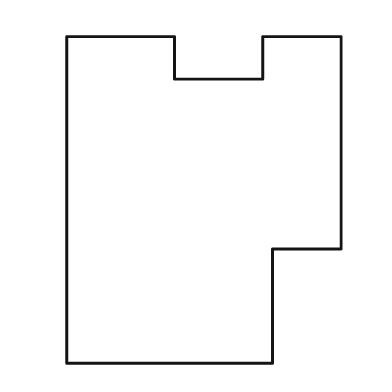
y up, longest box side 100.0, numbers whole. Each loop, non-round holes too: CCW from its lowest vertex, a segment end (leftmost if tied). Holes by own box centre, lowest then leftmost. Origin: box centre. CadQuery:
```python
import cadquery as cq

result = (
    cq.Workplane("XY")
    .moveTo(-42.0, -50.0)
    .lineTo(21.0, -50.0)
    .lineTo(21.0, -15.0)
    .lineTo(42.0, -15.0)
    .lineTo(42.0, 50.0)
    .lineTo(18.0, 50.0)
    .lineTo(18.0, 37.0)
    .lineTo(-9.0, 37.0)
    .lineTo(-9.0, 50.0)
    .lineTo(-42.0, 50.0)
    .close()
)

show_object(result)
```